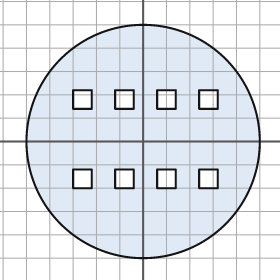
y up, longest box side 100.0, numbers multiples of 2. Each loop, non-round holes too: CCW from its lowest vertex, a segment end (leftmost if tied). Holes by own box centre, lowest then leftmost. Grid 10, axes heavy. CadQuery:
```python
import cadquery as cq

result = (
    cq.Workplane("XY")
    .moveTo(0.0, 0.0)
    .circle(50.0)
    .moveTo(-30.0, -20.0)
    .lineTo(-22.0, -20.0)
    .lineTo(-22.0, -12.0)
    .lineTo(-30.0, -12.0)
    .close()
    .moveTo(-12.0, -20.0)
    .lineTo(-4.0, -20.0)
    .lineTo(-4.0, -12.0)
    .lineTo(-12.0, -12.0)
    .close()
    .moveTo(6.0, -20.0)
    .lineTo(14.0, -20.0)
    .lineTo(14.0, -12.0)
    .lineTo(6.0, -12.0)
    .close()
    .moveTo(24.0, -20.0)
    .lineTo(32.0, -20.0)
    .lineTo(32.0, -12.0)
    .lineTo(24.0, -12.0)
    .close()
    .moveTo(-30.0, 14.0)
    .lineTo(-22.0, 14.0)
    .lineTo(-22.0, 22.0)
    .lineTo(-30.0, 22.0)
    .close()
    .moveTo(-12.0, 14.0)
    .lineTo(-4.0, 14.0)
    .lineTo(-4.0, 22.0)
    .lineTo(-12.0, 22.0)
    .close()
    .moveTo(6.0, 14.0)
    .lineTo(14.0, 14.0)
    .lineTo(14.0, 22.0)
    .lineTo(6.0, 22.0)
    .close()
    .moveTo(24.0, 14.0)
    .lineTo(32.0, 14.0)
    .lineTo(32.0, 22.0)
    .lineTo(24.0, 22.0)
    .close()
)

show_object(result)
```